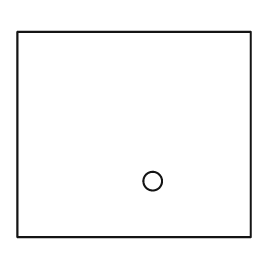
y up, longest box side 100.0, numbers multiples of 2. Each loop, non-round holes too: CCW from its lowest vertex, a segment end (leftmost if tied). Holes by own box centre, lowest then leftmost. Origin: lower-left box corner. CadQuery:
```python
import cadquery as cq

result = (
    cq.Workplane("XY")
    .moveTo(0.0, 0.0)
    .lineTo(100.0, 0.0)
    .lineTo(100.0, 88.0)
    .lineTo(0.0, 88.0)
    .close()
    .moveTo(58.0, 24.0)
    .circle(4.0)
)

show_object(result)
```